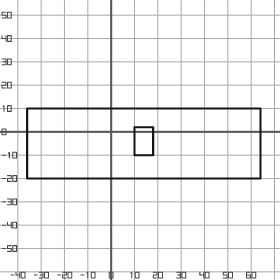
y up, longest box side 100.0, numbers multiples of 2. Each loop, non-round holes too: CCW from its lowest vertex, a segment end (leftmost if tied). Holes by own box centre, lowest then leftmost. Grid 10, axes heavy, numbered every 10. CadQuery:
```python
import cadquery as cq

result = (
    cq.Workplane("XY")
    .moveTo(-36.0, -20.0)
    .lineTo(64.0, -20.0)
    .lineTo(64.0, 10.0)
    .lineTo(-36.0, 10.0)
    .close()
    .moveTo(10.0, -10.0)
    .lineTo(18.0, -10.0)
    .lineTo(18.0, 2.0)
    .lineTo(10.0, 2.0)
    .close()
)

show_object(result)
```